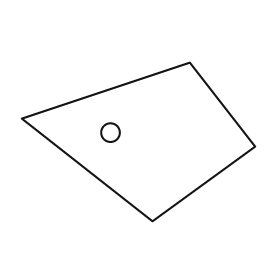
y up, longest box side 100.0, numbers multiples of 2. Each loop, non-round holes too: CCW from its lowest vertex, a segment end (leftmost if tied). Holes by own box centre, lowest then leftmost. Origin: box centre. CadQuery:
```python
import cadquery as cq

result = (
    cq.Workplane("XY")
    .moveTo(6.0, -34.0)
    .lineTo(50.0, -2.0)
    .lineTo(22.0, 34.0)
    .lineTo(-50.0, 10.0)
    .close()
    .moveTo(-12.0, 4.0)
    .circle(4.0)
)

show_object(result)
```